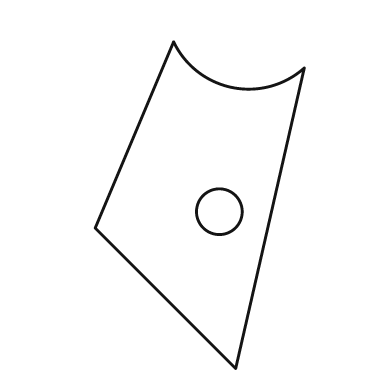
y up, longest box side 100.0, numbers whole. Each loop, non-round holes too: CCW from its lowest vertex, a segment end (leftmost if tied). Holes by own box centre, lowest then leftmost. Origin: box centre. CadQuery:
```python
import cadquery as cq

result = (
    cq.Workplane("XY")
    .moveTo(11.0, -50.0)
    .lineTo(32.0, 42.0)
    .threePointArc((10.0, 36.0), (-8.0, 50.0))
    .lineTo(-32.0, -7.0)
    .close()
    .moveTo(6.0, -2.0)
    .circle(7.0)
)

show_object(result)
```